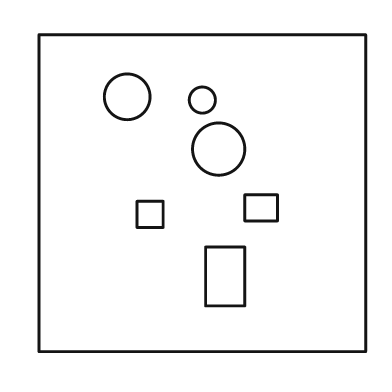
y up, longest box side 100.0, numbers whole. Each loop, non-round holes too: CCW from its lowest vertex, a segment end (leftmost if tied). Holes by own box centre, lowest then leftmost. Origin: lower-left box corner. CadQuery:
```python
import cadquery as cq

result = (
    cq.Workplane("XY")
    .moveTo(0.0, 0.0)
    .lineTo(100.0, 0.0)
    .lineTo(100.0, 97.0)
    .lineTo(0.0, 97.0)
    .close()
    .moveTo(51.0, 14.0)
    .lineTo(63.0, 14.0)
    .lineTo(63.0, 32.0)
    .lineTo(51.0, 32.0)
    .close()
    .moveTo(30.0, 38.0)
    .lineTo(38.0, 38.0)
    .lineTo(38.0, 46.0)
    .lineTo(30.0, 46.0)
    .close()
    .moveTo(63.0, 40.0)
    .lineTo(73.0, 40.0)
    .lineTo(73.0, 48.0)
    .lineTo(63.0, 48.0)
    .close()
    .moveTo(55.0, 62.0)
    .circle(8.0)
    .moveTo(50.0, 77.0)
    .circle(4.0)
    .moveTo(27.0, 78.0)
    .circle(7.0)
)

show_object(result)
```